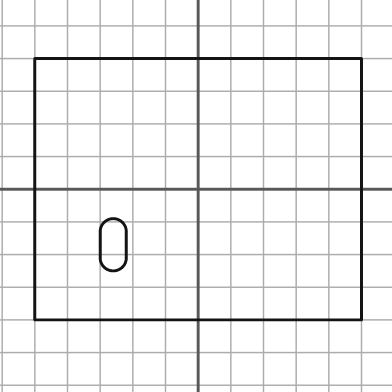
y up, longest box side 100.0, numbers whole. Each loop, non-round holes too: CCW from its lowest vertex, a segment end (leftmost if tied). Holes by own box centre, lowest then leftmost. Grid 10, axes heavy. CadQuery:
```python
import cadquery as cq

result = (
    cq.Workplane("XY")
    .moveTo(-50.0, -40.0)
    .lineTo(50.0, -40.0)
    .lineTo(50.0, 40.0)
    .lineTo(-50.0, 40.0)
    .close()
    .moveTo(-30.0, -21.0)
    .threePointArc((-26.0, -25.0), (-22.0, -21.0))
    .lineTo(-22.0, -13.0)
    .threePointArc((-26.0, -9.0), (-30.0, -13.0))
    .close()
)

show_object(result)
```